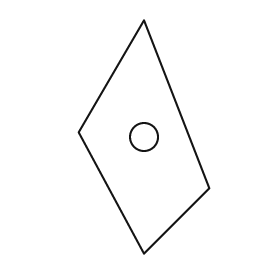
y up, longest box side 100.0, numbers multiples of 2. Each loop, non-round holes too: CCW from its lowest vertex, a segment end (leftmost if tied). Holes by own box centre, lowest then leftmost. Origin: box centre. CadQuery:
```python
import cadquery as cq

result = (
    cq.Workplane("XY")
    .moveTo(0.0, -50.0)
    .lineTo(28.0, -22.0)
    .lineTo(0.0, 50.0)
    .lineTo(-28.0, 2.0)
    .close()
    .moveTo(0.0, 0.0)
    .circle(6.0)
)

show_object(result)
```